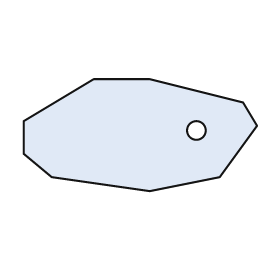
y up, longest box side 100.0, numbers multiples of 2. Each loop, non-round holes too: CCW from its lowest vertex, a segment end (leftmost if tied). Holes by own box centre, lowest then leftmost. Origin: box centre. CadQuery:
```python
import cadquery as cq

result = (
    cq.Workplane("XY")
    .moveTo(4.0, -24.0)
    .lineTo(34.0, -18.0)
    .lineTo(50.0, 4.0)
    .lineTo(44.0, 14.0)
    .lineTo(4.0, 24.0)
    .lineTo(-20.0, 24.0)
    .lineTo(-50.0, 6.0)
    .lineTo(-50.0, -8.0)
    .lineTo(-38.0, -18.0)
    .close()
    .moveTo(24.0, 2.0)
    .circle(4.0)
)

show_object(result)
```